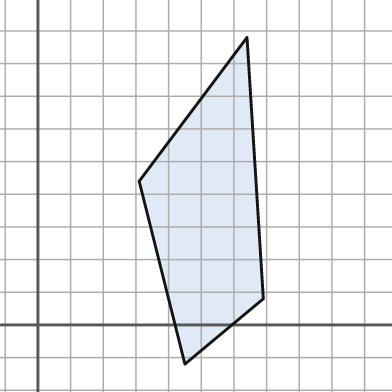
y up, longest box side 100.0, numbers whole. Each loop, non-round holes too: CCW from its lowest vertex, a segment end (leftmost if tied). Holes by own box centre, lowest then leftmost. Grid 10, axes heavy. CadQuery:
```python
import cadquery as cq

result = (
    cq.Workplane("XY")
    .moveTo(45.0, -12.0)
    .lineTo(69.0, 8.0)
    .lineTo(64.0, 88.0)
    .lineTo(31.0, 44.0)
    .close()
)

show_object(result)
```